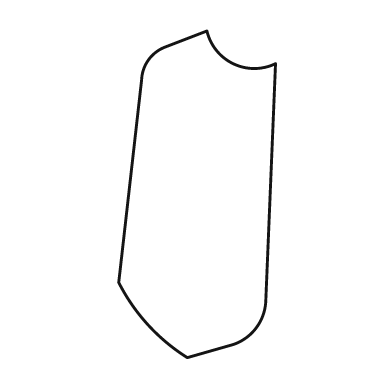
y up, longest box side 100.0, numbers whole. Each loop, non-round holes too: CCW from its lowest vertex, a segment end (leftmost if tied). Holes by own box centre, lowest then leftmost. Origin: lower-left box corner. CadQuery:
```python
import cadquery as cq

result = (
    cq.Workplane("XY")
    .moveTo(21.0, 0.0)
    .lineTo(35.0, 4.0)
    .threePointArc((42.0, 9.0), (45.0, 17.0))
    .lineTo(48.0, 90.0)
    .threePointArc((35.0, 90.0), (27.0, 100.0))
    .lineTo(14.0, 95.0)
    .threePointArc((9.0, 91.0), (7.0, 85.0))
    .lineTo(0.0, 23.0)
    .threePointArc((9.0, 10.0), (21.0, 0.0))
    .close()
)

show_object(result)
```